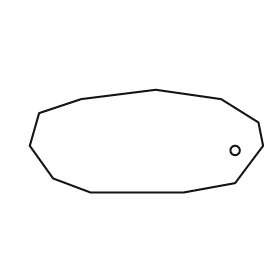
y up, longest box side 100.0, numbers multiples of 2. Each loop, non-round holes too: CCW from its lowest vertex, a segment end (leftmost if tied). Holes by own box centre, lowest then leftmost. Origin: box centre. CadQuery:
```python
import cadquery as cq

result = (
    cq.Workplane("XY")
    .moveTo(-24.0, -22.0)
    .lineTo(16.0, -22.0)
    .lineTo(38.0, -18.0)
    .lineTo(50.0, -2.0)
    .lineTo(48.0, 8.0)
    .lineTo(32.0, 18.0)
    .lineTo(4.0, 22.0)
    .lineTo(-28.0, 18.0)
    .lineTo(-46.0, 12.0)
    .lineTo(-50.0, -2.0)
    .lineTo(-40.0, -16.0)
    .close()
    .moveTo(38.0, -4.0)
    .circle(2.0)
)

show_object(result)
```